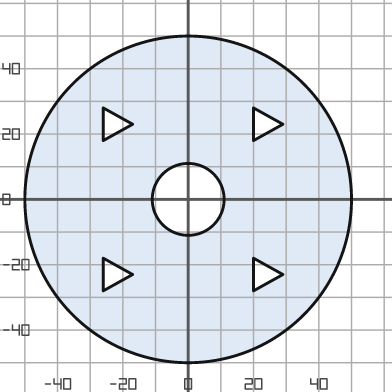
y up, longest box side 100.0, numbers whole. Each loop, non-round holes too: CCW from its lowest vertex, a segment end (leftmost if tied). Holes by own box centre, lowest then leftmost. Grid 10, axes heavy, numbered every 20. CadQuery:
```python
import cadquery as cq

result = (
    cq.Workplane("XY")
    .moveTo(0.0, 0.0)
    .circle(50.0)
    .moveTo(-26.0, -28.0)
    .lineTo(-17.0, -23.0)
    .lineTo(-26.0, -18.0)
    .close()
    .moveTo(20.0, -28.0)
    .lineTo(29.0, -23.0)
    .lineTo(20.0, -18.0)
    .close()
    .moveTo(0.0, 0.0)
    .circle(11.0)
    .moveTo(-26.0, 18.0)
    .lineTo(-17.0, 23.0)
    .lineTo(-26.0, 28.0)
    .close()
    .moveTo(20.0, 18.0)
    .lineTo(29.0, 23.0)
    .lineTo(20.0, 28.0)
    .close()
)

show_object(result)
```